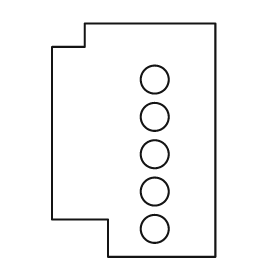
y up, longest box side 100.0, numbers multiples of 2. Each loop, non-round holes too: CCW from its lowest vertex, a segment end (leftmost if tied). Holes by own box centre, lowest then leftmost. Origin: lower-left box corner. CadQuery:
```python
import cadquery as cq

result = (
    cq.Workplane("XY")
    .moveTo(24.0, 0.0)
    .lineTo(70.0, 0.0)
    .lineTo(70.0, 100.0)
    .lineTo(14.0, 100.0)
    .lineTo(14.0, 90.0)
    .lineTo(0.0, 90.0)
    .lineTo(0.0, 16.0)
    .lineTo(24.0, 16.0)
    .close()
    .moveTo(44.0, 12.0)
    .circle(6.0)
    .moveTo(44.0, 28.0)
    .circle(6.0)
    .moveTo(44.0, 44.0)
    .circle(6.0)
    .moveTo(44.0, 60.0)
    .circle(6.0)
    .moveTo(44.0, 76.0)
    .circle(6.0)
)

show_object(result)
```